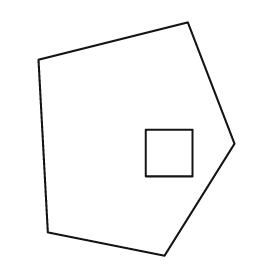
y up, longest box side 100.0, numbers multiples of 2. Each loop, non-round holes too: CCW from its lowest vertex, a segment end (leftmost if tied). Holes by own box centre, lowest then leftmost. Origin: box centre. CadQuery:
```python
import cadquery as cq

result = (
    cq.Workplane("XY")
    .moveTo(12.0, -50.0)
    .lineTo(42.0, -2.0)
    .lineTo(22.0, 50.0)
    .lineTo(-42.0, 34.0)
    .lineTo(-38.0, -40.0)
    .close()
    .moveTo(4.0, -16.0)
    .lineTo(24.0, -16.0)
    .lineTo(24.0, 4.0)
    .lineTo(4.0, 4.0)
    .close()
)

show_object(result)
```